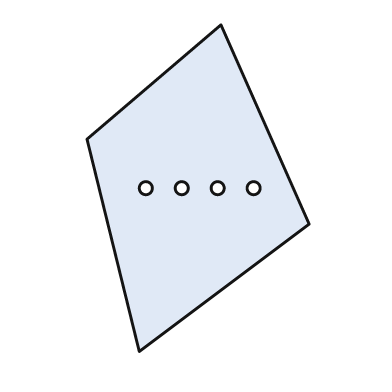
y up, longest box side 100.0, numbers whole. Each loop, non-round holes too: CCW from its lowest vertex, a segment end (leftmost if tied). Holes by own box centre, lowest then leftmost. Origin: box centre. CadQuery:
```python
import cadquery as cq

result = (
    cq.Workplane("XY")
    .moveTo(-18.0, -50.0)
    .lineTo(34.0, -11.0)
    .lineTo(7.0, 50.0)
    .lineTo(-34.0, 15.0)
    .close()
    .moveTo(-16.0, 0.0)
    .circle(2.0)
    .moveTo(-5.0, 0.0)
    .circle(2.0)
    .moveTo(6.0, 0.0)
    .circle(2.0)
    .moveTo(17.0, 0.0)
    .circle(2.0)
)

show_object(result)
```